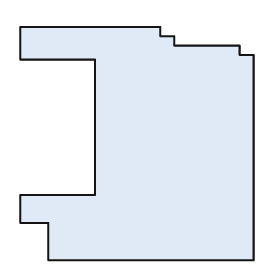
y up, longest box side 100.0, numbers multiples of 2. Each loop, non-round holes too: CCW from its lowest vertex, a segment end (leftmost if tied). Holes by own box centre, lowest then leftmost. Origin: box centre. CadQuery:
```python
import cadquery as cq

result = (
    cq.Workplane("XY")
    .moveTo(-38.0, -50.0)
    .lineTo(50.0, -50.0)
    .lineTo(50.0, 38.0)
    .lineTo(44.0, 38.0)
    .lineTo(44.0, 42.0)
    .lineTo(16.0, 42.0)
    .lineTo(16.0, 46.0)
    .lineTo(10.0, 46.0)
    .lineTo(10.0, 50.0)
    .lineTo(-50.0, 50.0)
    .lineTo(-50.0, 36.0)
    .lineTo(-18.0, 36.0)
    .lineTo(-18.0, -22.0)
    .lineTo(-50.0, -22.0)
    .lineTo(-50.0, -34.0)
    .lineTo(-38.0, -34.0)
    .close()
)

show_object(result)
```